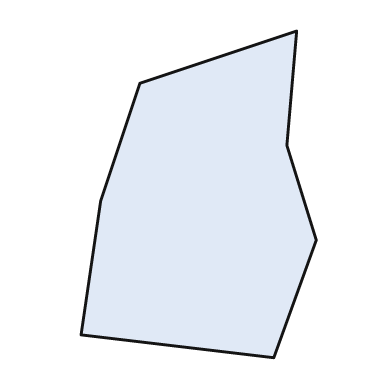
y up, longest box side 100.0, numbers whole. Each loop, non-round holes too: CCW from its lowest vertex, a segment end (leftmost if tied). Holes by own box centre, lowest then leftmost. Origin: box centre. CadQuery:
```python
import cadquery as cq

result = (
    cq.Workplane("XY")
    .moveTo(23.0, -50.0)
    .lineTo(36.0, -14.0)
    .lineTo(27.0, 15.0)
    .lineTo(30.0, 50.0)
    .lineTo(-18.0, 34.0)
    .lineTo(-30.0, -2.0)
    .lineTo(-36.0, -43.0)
    .close()
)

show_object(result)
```